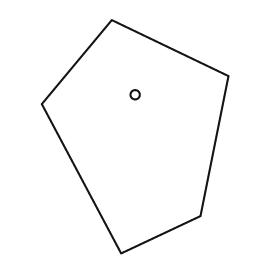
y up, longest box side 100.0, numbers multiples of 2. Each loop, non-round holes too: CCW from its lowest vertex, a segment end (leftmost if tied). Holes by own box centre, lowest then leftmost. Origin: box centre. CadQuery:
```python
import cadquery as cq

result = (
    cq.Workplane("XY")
    .moveTo(-6.0, -50.0)
    .lineTo(28.0, -34.0)
    .lineTo(40.0, 26.0)
    .lineTo(-10.0, 50.0)
    .lineTo(-40.0, 14.0)
    .close()
    .moveTo(0.0, 18.0)
    .circle(2.0)
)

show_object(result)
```